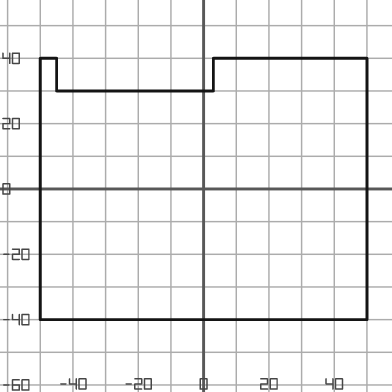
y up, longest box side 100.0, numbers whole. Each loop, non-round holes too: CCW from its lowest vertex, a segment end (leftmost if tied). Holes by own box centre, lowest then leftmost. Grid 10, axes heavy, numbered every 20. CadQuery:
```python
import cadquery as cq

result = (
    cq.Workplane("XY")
    .moveTo(-50.0, -40.0)
    .lineTo(50.0, -40.0)
    .lineTo(50.0, 40.0)
    .lineTo(3.0, 40.0)
    .lineTo(3.0, 30.0)
    .lineTo(-45.0, 30.0)
    .lineTo(-45.0, 40.0)
    .lineTo(-50.0, 40.0)
    .close()
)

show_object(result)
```